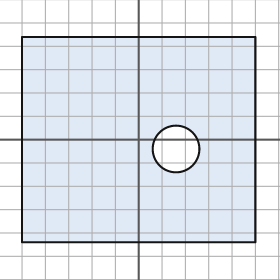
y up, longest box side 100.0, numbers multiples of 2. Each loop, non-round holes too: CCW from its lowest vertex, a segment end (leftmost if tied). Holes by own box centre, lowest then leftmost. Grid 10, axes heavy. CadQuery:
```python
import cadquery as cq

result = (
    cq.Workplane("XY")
    .moveTo(-50.0, -44.0)
    .lineTo(50.0, -44.0)
    .lineTo(50.0, 44.0)
    .lineTo(-50.0, 44.0)
    .close()
    .moveTo(16.0, -4.0)
    .circle(10.0)
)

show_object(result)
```